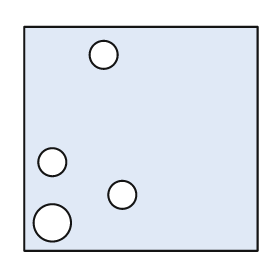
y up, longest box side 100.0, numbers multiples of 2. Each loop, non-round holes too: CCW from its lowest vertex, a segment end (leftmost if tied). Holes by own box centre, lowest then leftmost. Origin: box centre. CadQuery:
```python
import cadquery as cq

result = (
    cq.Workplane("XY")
    .moveTo(-50.0, -48.0)
    .lineTo(50.0, -48.0)
    .lineTo(50.0, 48.0)
    .lineTo(-50.0, 48.0)
    .close()
    .moveTo(-38.0, -36.0)
    .circle(8.0)
    .moveTo(-8.0, -24.0)
    .circle(6.0)
    .moveTo(-38.0, -10.0)
    .circle(6.0)
    .moveTo(-16.0, 36.0)
    .circle(6.0)
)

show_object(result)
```